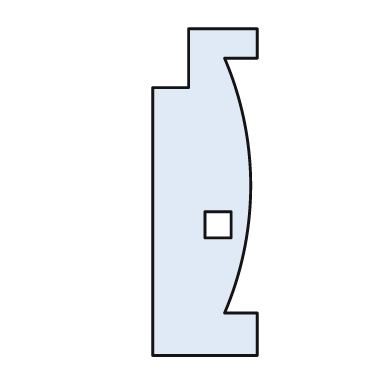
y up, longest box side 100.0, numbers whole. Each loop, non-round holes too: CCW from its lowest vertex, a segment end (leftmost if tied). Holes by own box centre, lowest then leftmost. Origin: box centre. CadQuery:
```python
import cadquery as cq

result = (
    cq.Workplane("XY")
    .moveTo(-16.0, -50.0)
    .lineTo(16.0, -50.0)
    .lineTo(16.0, -37.0)
    .lineTo(6.0, -37.0)
    .threePointArc((14.0, 2.0), (6.0, 41.0))
    .lineTo(16.0, 41.0)
    .lineTo(16.0, 50.0)
    .lineTo(-5.0, 50.0)
    .lineTo(-5.0, 32.0)
    .lineTo(-16.0, 32.0)
    .close()
    .moveTo(0.0, -14.0)
    .lineTo(8.0, -14.0)
    .lineTo(8.0, -6.0)
    .lineTo(0.0, -6.0)
    .close()
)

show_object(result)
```